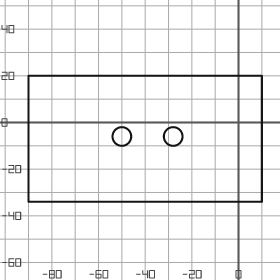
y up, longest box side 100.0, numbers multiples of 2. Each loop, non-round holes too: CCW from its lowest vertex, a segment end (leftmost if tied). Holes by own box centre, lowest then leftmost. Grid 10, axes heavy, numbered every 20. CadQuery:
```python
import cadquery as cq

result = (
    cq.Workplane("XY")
    .moveTo(-90.0, -34.0)
    .lineTo(10.0, -34.0)
    .lineTo(10.0, 20.0)
    .lineTo(-90.0, 20.0)
    .close()
    .moveTo(-50.0, -6.0)
    .circle(4.0)
    .moveTo(-28.0, -6.0)
    .circle(4.0)
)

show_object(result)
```